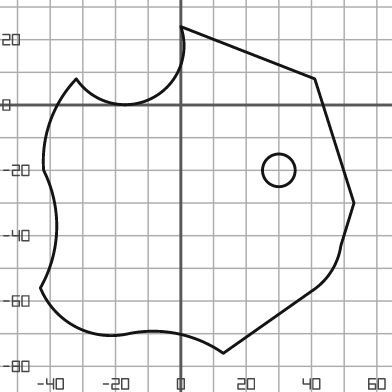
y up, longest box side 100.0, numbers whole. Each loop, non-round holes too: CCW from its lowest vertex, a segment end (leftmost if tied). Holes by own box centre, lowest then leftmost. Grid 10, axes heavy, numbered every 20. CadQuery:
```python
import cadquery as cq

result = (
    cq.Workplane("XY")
    .moveTo(13.0, -76.0)
    .lineTo(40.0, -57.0)
    .threePointArc((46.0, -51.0), (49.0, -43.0))
    .lineTo(53.0, -30.0)
    .lineTo(41.0, 8.0)
    .lineTo(0.0, 24.0)
    .threePointArc((-9.0, 2.0), (-32.0, 8.0))
    .threePointArc((-40.0, -5.0), (-42.0, -20.0))
    .threePointArc((-38.0, -38.0), (-43.0, -56.0))
    .threePointArc((-32.0, -68.0), (-16.0, -70.0))
    .threePointArc((-1.0, -70.0), (13.0, -76.0))
    .close()
    .moveTo(30.0, -20.0)
    .circle(5.0)
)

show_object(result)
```